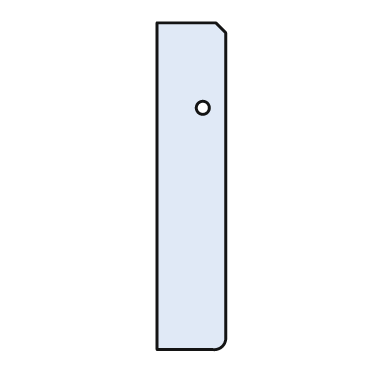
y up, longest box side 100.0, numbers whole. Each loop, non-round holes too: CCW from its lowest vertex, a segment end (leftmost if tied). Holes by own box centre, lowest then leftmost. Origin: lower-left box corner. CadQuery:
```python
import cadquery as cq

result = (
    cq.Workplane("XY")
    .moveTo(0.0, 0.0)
    .lineTo(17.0, 0.0)
    .threePointArc((20.0, 1.0), (21.0, 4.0))
    .lineTo(21.0, 97.0)
    .lineTo(18.0, 100.0)
    .lineTo(0.0, 100.0)
    .close()
    .moveTo(14.0, 74.0)
    .circle(2.0)
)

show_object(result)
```